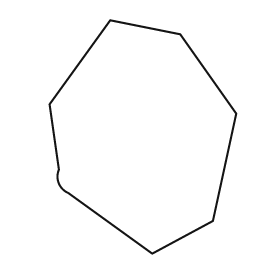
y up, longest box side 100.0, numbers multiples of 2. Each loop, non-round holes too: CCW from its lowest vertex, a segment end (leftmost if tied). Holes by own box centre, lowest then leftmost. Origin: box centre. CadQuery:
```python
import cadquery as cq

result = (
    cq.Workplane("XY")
    .moveTo(4.0, -50.0)
    .lineTo(30.0, -36.0)
    .lineTo(40.0, 10.0)
    .lineTo(16.0, 44.0)
    .lineTo(-14.0, 50.0)
    .lineTo(-40.0, 14.0)
    .lineTo(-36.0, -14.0)
    .threePointArc((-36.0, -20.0), (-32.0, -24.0))
    .close()
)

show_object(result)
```